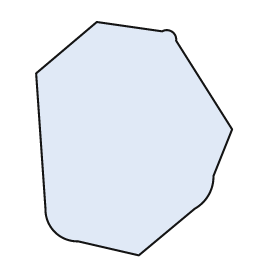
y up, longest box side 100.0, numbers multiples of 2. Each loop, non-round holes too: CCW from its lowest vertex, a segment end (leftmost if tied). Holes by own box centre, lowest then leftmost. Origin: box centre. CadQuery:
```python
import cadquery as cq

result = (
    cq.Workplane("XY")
    .moveTo(2.0, -50.0)
    .lineTo(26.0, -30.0)
    .threePointArc((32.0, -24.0), (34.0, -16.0))
    .lineTo(42.0, 4.0)
    .lineTo(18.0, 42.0)
    .threePointArc((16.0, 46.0), (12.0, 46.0))
    .lineTo(-16.0, 50.0)
    .lineTo(-42.0, 28.0)
    .lineTo(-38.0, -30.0)
    .threePointArc((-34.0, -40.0), (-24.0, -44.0))
    .close()
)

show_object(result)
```